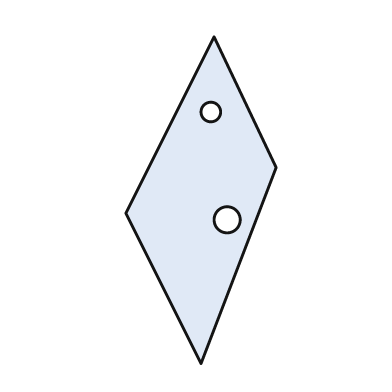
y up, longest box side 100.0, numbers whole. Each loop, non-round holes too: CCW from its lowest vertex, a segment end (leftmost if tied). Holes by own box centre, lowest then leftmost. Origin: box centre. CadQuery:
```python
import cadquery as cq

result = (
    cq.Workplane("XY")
    .moveTo(0.0, -50.0)
    .lineTo(23.0, 10.0)
    .lineTo(4.0, 50.0)
    .lineTo(-23.0, -4.0)
    .close()
    .moveTo(8.0, -6.0)
    .circle(4.0)
    .moveTo(3.0, 27.0)
    .circle(3.0)
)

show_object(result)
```